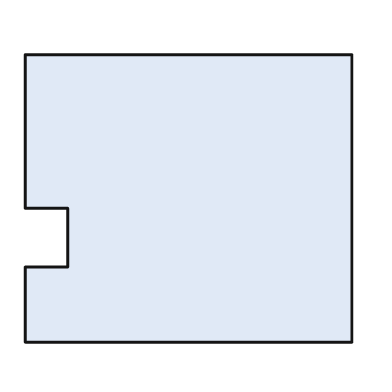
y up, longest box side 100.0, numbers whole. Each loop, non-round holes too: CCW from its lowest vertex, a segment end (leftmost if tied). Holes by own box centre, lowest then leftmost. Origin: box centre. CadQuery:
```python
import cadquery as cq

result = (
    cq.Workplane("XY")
    .moveTo(-50.0, -44.0)
    .lineTo(50.0, -44.0)
    .lineTo(50.0, 44.0)
    .lineTo(-50.0, 44.0)
    .lineTo(-50.0, -3.0)
    .lineTo(-37.0, -3.0)
    .lineTo(-37.0, -21.0)
    .lineTo(-50.0, -21.0)
    .close()
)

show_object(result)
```